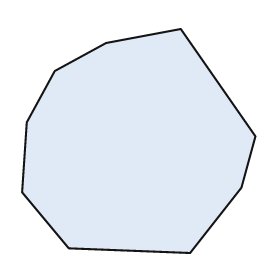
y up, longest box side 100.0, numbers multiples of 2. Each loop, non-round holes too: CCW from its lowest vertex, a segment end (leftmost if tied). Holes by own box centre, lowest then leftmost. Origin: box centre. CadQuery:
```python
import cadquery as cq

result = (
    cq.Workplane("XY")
    .moveTo(22.0, -48.0)
    .lineTo(44.0, -20.0)
    .lineTo(50.0, 2.0)
    .lineTo(18.0, 48.0)
    .lineTo(-14.0, 42.0)
    .lineTo(-36.0, 30.0)
    .lineTo(-48.0, 8.0)
    .lineTo(-50.0, -22.0)
    .lineTo(-30.0, -46.0)
    .close()
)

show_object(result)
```